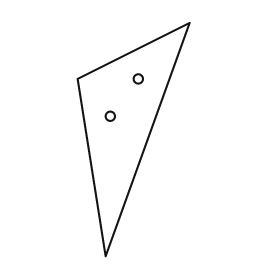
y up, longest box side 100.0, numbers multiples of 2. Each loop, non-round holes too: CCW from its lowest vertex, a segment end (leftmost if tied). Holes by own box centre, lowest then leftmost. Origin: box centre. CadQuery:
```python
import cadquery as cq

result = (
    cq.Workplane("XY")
    .moveTo(-12.0, -50.0)
    .lineTo(24.0, 50.0)
    .lineTo(-24.0, 26.0)
    .close()
    .moveTo(-10.0, 10.0)
    .circle(2.0)
    .moveTo(2.0, 26.0)
    .circle(2.0)
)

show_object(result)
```